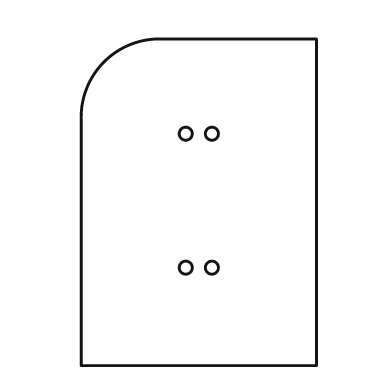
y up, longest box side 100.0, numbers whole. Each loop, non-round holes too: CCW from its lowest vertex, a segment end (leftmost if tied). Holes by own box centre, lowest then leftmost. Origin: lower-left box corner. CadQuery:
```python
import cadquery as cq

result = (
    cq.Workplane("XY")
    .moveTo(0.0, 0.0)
    .lineTo(72.0, 0.0)
    .lineTo(72.0, 100.0)
    .lineTo(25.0, 100.0)
    .threePointArc((7.0, 93.0), (0.0, 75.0))
    .close()
    .moveTo(32.0, 30.0)
    .circle(2.0)
    .moveTo(40.0, 30.0)
    .circle(2.0)
    .moveTo(32.0, 71.0)
    .circle(2.0)
    .moveTo(40.0, 71.0)
    .circle(2.0)
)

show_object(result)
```